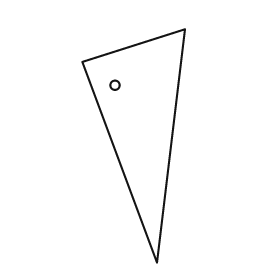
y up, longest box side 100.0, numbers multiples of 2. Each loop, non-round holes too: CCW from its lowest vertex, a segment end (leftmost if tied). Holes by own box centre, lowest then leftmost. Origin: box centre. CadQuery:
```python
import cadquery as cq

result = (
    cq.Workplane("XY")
    .moveTo(10.0, -50.0)
    .lineTo(22.0, 50.0)
    .lineTo(-22.0, 36.0)
    .close()
    .moveTo(-8.0, 26.0)
    .circle(2.0)
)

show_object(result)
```